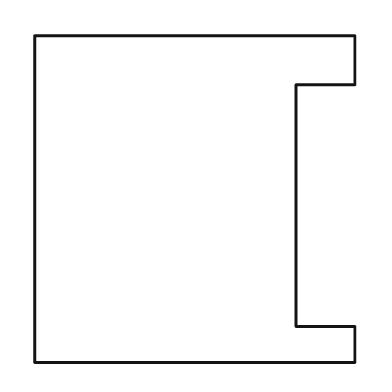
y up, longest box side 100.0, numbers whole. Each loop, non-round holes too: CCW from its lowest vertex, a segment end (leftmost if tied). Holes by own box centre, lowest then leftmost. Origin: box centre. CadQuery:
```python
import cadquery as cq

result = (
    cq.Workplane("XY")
    .moveTo(-49.0, -50.0)
    .lineTo(49.0, -50.0)
    .lineTo(49.0, -39.0)
    .lineTo(31.0, -39.0)
    .lineTo(31.0, 35.0)
    .lineTo(49.0, 35.0)
    .lineTo(49.0, 50.0)
    .lineTo(-49.0, 50.0)
    .close()
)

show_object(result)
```